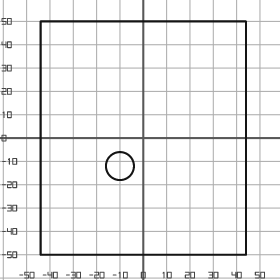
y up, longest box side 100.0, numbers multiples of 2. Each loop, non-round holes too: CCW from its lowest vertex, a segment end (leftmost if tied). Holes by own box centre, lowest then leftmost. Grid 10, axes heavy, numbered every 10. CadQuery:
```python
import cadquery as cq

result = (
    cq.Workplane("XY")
    .moveTo(-44.0, -50.0)
    .lineTo(44.0, -50.0)
    .lineTo(44.0, 50.0)
    .lineTo(-44.0, 50.0)
    .close()
    .moveTo(-10.0, -12.0)
    .circle(6.0)
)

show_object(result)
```